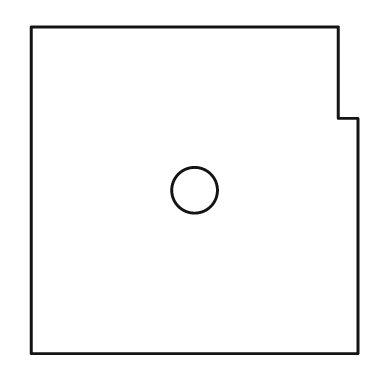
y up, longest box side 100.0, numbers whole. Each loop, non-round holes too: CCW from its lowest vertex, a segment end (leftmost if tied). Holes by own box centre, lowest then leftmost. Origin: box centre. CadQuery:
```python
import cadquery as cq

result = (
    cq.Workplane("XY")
    .moveTo(-50.0, -50.0)
    .lineTo(50.0, -50.0)
    .lineTo(50.0, 22.0)
    .lineTo(44.0, 22.0)
    .lineTo(44.0, 50.0)
    .lineTo(-50.0, 50.0)
    .close()
    .moveTo(0.0, 0.0)
    .circle(7.0)
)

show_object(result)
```